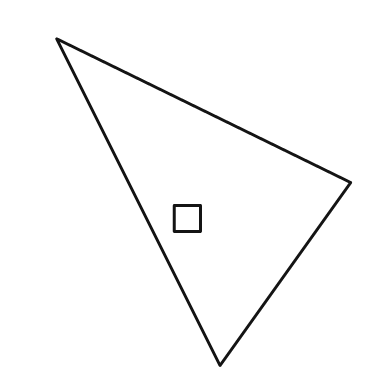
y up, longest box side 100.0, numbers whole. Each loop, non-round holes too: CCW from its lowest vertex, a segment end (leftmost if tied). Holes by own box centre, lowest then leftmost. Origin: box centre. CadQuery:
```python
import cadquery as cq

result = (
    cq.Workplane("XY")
    .moveTo(5.0, -50.0)
    .lineTo(45.0, 6.0)
    .lineTo(-45.0, 50.0)
    .close()
    .moveTo(-9.0, -9.0)
    .lineTo(-1.0, -9.0)
    .lineTo(-1.0, -1.0)
    .lineTo(-9.0, -1.0)
    .close()
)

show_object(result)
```